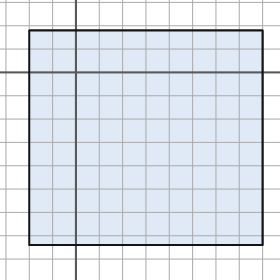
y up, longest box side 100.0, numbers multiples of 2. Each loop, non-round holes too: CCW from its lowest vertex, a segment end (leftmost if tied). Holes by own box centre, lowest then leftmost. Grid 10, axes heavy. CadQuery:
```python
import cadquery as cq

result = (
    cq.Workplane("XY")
    .moveTo(-20.0, -74.0)
    .lineTo(80.0, -74.0)
    .lineTo(80.0, 18.0)
    .lineTo(-20.0, 18.0)
    .close()
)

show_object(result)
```